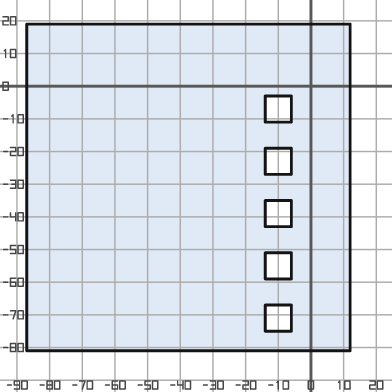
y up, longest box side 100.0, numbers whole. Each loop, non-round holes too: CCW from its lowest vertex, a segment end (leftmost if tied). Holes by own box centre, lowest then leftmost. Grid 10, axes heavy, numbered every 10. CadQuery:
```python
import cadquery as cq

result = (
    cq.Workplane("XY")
    .moveTo(-87.0, -81.0)
    .lineTo(12.0, -81.0)
    .lineTo(12.0, 19.0)
    .lineTo(-87.0, 19.0)
    .close()
    .moveTo(-14.0, -75.0)
    .lineTo(-6.0, -75.0)
    .lineTo(-6.0, -67.0)
    .lineTo(-14.0, -67.0)
    .close()
    .moveTo(-14.0, -59.0)
    .lineTo(-6.0, -59.0)
    .lineTo(-6.0, -51.0)
    .lineTo(-14.0, -51.0)
    .close()
    .moveTo(-14.0, -43.0)
    .lineTo(-6.0, -43.0)
    .lineTo(-6.0, -35.0)
    .lineTo(-14.0, -35.0)
    .close()
    .moveTo(-14.0, -27.0)
    .lineTo(-6.0, -27.0)
    .lineTo(-6.0, -19.0)
    .lineTo(-14.0, -19.0)
    .close()
    .moveTo(-14.0, -11.0)
    .lineTo(-6.0, -11.0)
    .lineTo(-6.0, -3.0)
    .lineTo(-14.0, -3.0)
    .close()
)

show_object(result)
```